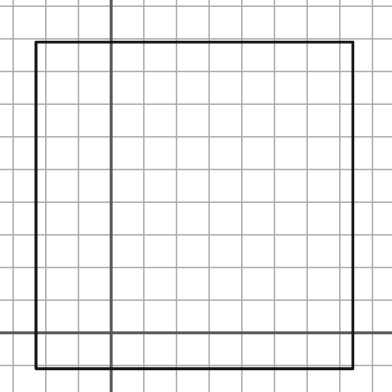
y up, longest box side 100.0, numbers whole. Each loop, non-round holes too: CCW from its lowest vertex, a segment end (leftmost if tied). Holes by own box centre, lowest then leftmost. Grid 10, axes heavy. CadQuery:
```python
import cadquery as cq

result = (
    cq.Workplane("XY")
    .moveTo(-23.0, -11.0)
    .lineTo(74.0, -11.0)
    .lineTo(74.0, 89.0)
    .lineTo(-23.0, 89.0)
    .close()
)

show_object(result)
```